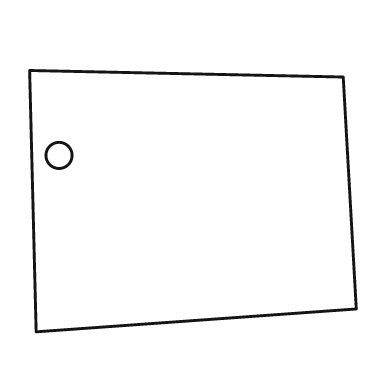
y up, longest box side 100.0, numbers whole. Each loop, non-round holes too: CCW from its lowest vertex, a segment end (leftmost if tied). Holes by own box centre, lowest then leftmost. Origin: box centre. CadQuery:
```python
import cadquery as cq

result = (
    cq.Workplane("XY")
    .moveTo(-48.0, -40.0)
    .lineTo(50.0, -33.0)
    .lineTo(46.0, 38.0)
    .lineTo(-50.0, 40.0)
    .close()
    .moveTo(-41.0, 14.0)
    .circle(4.0)
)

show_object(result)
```